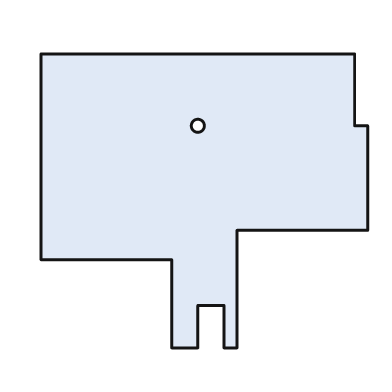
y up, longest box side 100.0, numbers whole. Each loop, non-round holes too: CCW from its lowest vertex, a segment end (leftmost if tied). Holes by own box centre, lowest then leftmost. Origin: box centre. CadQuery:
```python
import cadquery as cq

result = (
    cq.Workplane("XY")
    .moveTo(-10.0, -45.0)
    .lineTo(-2.0, -45.0)
    .lineTo(-2.0, -32.0)
    .lineTo(6.0, -32.0)
    .lineTo(6.0, -45.0)
    .lineTo(10.0, -45.0)
    .lineTo(10.0, -9.0)
    .lineTo(50.0, -9.0)
    .lineTo(50.0, 23.0)
    .lineTo(46.0, 23.0)
    .lineTo(46.0, 45.0)
    .lineTo(-50.0, 45.0)
    .lineTo(-50.0, -18.0)
    .lineTo(-10.0, -18.0)
    .close()
    .moveTo(-2.0, 23.0)
    .circle(2.0)
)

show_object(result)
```